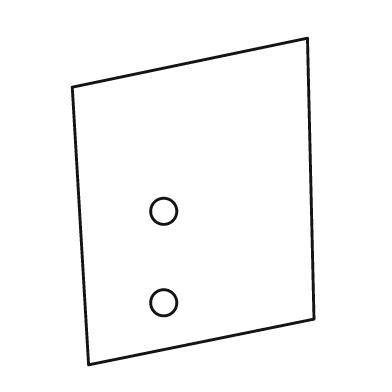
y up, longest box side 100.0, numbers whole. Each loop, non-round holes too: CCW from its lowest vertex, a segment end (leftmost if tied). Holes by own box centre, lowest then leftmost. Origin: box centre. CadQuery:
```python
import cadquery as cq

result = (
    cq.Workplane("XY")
    .moveTo(-32.0, -50.0)
    .lineTo(37.0, -36.0)
    .lineTo(35.0, 50.0)
    .lineTo(-37.0, 35.0)
    .close()
    .moveTo(-9.0, -31.0)
    .circle(4.0)
    .moveTo(-9.0, -3.0)
    .circle(4.0)
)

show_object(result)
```